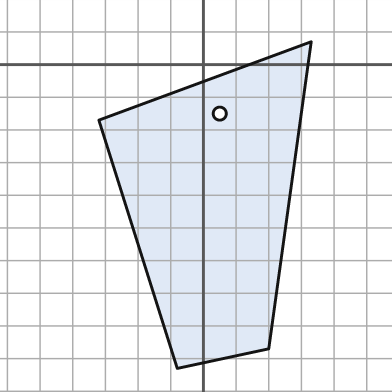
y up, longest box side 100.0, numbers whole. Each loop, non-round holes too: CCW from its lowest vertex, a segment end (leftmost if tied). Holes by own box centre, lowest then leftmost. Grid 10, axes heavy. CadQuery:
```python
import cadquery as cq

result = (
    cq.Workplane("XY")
    .moveTo(-8.0, -93.0)
    .lineTo(20.0, -87.0)
    .lineTo(33.0, 7.0)
    .lineTo(-32.0, -17.0)
    .close()
    .moveTo(5.0, -15.0)
    .circle(2.0)
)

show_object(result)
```